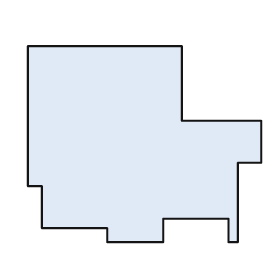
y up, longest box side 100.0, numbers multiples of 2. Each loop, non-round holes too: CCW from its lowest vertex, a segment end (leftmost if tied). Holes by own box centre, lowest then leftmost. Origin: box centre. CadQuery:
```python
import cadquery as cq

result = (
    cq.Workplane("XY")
    .moveTo(-16.0, -42.0)
    .lineTo(8.0, -42.0)
    .lineTo(8.0, -32.0)
    .lineTo(36.0, -32.0)
    .lineTo(36.0, -42.0)
    .lineTo(40.0, -42.0)
    .lineTo(40.0, -8.0)
    .lineTo(50.0, -8.0)
    .lineTo(50.0, 10.0)
    .lineTo(16.0, 10.0)
    .lineTo(16.0, 42.0)
    .lineTo(-50.0, 42.0)
    .lineTo(-50.0, -18.0)
    .lineTo(-44.0, -18.0)
    .lineTo(-44.0, -36.0)
    .lineTo(-16.0, -36.0)
    .close()
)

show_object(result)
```